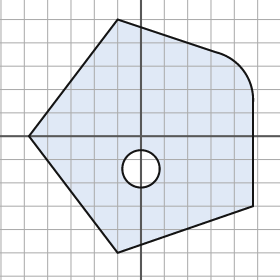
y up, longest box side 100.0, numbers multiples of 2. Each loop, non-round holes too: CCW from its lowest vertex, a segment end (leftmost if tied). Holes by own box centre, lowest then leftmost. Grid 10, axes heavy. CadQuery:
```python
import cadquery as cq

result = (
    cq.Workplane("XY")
    .moveTo(-10.0, -50.0)
    .lineTo(48.0, -30.0)
    .lineTo(48.0, 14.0)
    .threePointArc((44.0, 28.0), (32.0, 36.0))
    .lineTo(-10.0, 50.0)
    .lineTo(-48.0, 0.0)
    .close()
    .moveTo(0.0, -14.0)
    .circle(8.0)
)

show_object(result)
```